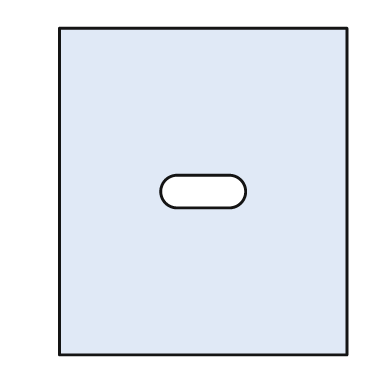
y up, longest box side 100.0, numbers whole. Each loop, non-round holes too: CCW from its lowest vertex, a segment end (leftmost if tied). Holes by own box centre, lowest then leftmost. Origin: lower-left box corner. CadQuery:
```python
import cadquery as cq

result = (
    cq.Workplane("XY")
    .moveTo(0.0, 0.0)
    .lineTo(88.0, 0.0)
    .lineTo(88.0, 100.0)
    .lineTo(0.0, 100.0)
    .close()
    .moveTo(36.0, 45.0)
    .lineTo(52.0, 45.0)
    .threePointArc((57.0, 50.0), (52.0, 55.0))
    .lineTo(36.0, 55.0)
    .threePointArc((31.0, 50.0), (36.0, 45.0))
    .close()
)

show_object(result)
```